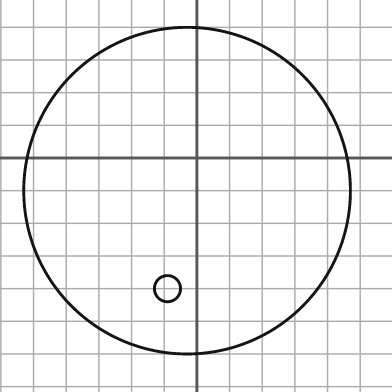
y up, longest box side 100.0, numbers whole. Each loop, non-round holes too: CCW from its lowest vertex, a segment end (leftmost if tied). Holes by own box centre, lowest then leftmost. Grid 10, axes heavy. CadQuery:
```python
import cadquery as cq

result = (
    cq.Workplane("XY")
    .moveTo(-3.0, -10.0)
    .circle(50.0)
    .moveTo(-9.0, -40.0)
    .circle(4.0)
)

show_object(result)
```